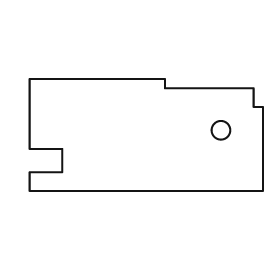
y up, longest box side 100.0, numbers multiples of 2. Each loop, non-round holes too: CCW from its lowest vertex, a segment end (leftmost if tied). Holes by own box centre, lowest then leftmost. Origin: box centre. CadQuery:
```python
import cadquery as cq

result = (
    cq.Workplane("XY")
    .moveTo(-50.0, -24.0)
    .lineTo(50.0, -24.0)
    .lineTo(50.0, 12.0)
    .lineTo(46.0, 12.0)
    .lineTo(46.0, 20.0)
    .lineTo(8.0, 20.0)
    .lineTo(8.0, 24.0)
    .lineTo(-50.0, 24.0)
    .lineTo(-50.0, -6.0)
    .lineTo(-36.0, -6.0)
    .lineTo(-36.0, -16.0)
    .lineTo(-50.0, -16.0)
    .close()
    .moveTo(32.0, 2.0)
    .circle(4.0)
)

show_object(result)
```